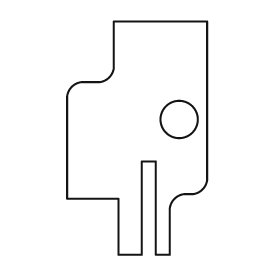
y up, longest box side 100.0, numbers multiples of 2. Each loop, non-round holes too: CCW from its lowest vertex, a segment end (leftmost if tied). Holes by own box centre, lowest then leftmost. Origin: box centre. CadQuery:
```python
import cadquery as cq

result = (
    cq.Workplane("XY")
    .moveTo(-8.0, -50.0)
    .lineTo(2.0, -50.0)
    .lineTo(2.0, -10.0)
    .lineTo(8.0, -10.0)
    .lineTo(8.0, -50.0)
    .lineTo(14.0, -50.0)
    .lineTo(14.0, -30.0)
    .threePointArc((16.0, -26.0), (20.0, -24.0))
    .lineTo(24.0, -24.0)
    .threePointArc((28.0, -22.0), (30.0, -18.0))
    .lineTo(30.0, 50.0)
    .lineTo(-10.0, 50.0)
    .lineTo(-10.0, 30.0)
    .threePointArc((-12.0, 26.0), (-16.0, 24.0))
    .lineTo(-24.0, 24.0)
    .threePointArc((-28.0, 22.0), (-30.0, 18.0))
    .lineTo(-30.0, -26.0)
    .lineTo(-8.0, -26.0)
    .close()
    .moveTo(18.0, 8.0)
    .circle(8.0)
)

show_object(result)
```